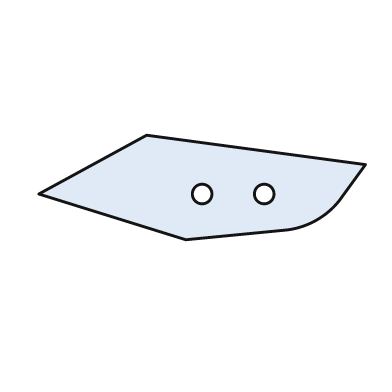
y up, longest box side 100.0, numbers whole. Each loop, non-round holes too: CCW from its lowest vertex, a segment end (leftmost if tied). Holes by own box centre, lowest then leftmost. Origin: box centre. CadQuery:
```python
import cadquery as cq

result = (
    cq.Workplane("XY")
    .moveTo(-5.0, -16.0)
    .lineTo(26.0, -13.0)
    .threePointArc((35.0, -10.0), (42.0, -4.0))
    .lineTo(50.0, 7.0)
    .lineTo(-17.0, 16.0)
    .lineTo(-50.0, -2.0)
    .close()
    .moveTo(0.0, -2.0)
    .circle(3.0)
    .moveTo(19.0, -2.0)
    .circle(3.0)
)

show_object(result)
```